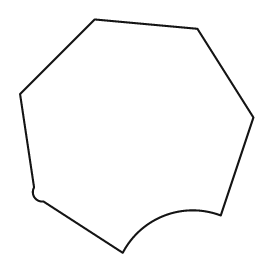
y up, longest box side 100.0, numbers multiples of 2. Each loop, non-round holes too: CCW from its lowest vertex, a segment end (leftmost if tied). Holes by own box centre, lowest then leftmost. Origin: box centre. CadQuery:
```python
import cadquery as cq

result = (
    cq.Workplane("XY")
    .moveTo(-6.0, -50.0)
    .threePointArc((12.0, -34.0), (36.0, -34.0))
    .lineTo(50.0, 8.0)
    .lineTo(26.0, 46.0)
    .lineTo(-18.0, 50.0)
    .lineTo(-50.0, 18.0)
    .lineTo(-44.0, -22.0)
    .threePointArc((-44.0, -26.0), (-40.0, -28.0))
    .close()
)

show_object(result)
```